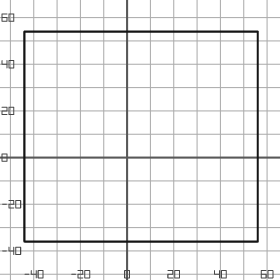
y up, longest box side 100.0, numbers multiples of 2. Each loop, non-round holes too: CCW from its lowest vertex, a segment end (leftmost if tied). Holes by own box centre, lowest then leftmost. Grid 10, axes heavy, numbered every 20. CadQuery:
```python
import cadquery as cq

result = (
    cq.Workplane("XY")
    .moveTo(-44.0, -36.0)
    .lineTo(56.0, -36.0)
    .lineTo(56.0, 54.0)
    .lineTo(-44.0, 54.0)
    .close()
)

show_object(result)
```